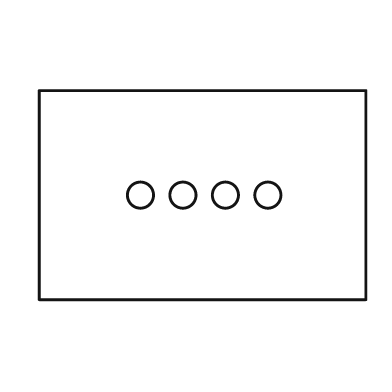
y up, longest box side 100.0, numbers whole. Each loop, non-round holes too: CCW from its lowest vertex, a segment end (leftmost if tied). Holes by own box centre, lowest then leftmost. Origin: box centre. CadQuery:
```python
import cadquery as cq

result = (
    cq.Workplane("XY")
    .moveTo(-50.0, -32.0)
    .lineTo(50.0, -32.0)
    .lineTo(50.0, 32.0)
    .lineTo(-50.0, 32.0)
    .close()
    .moveTo(-19.0, 0.0)
    .circle(4.0)
    .moveTo(-6.0, 0.0)
    .circle(4.0)
    .moveTo(7.0, 0.0)
    .circle(4.0)
    .moveTo(20.0, 0.0)
    .circle(4.0)
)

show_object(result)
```